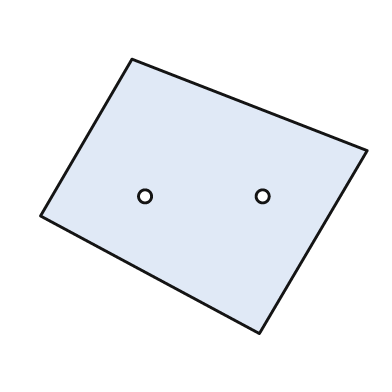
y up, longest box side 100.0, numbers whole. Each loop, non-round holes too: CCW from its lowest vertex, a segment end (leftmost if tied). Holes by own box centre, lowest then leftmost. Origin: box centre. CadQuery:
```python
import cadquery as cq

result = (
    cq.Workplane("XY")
    .moveTo(17.0, -42.0)
    .lineTo(50.0, 14.0)
    .lineTo(-22.0, 42.0)
    .lineTo(-50.0, -6.0)
    .close()
    .moveTo(-18.0, 0.0)
    .circle(2.0)
    .moveTo(18.0, 0.0)
    .circle(2.0)
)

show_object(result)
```